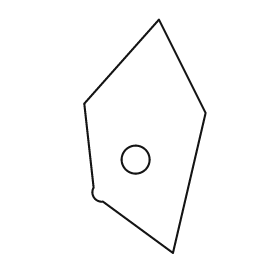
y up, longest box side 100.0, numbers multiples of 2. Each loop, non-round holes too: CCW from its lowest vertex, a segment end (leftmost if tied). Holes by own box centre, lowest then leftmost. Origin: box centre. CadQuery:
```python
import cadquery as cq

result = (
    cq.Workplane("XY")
    .moveTo(12.0, -50.0)
    .lineTo(26.0, 10.0)
    .lineTo(6.0, 50.0)
    .lineTo(-26.0, 14.0)
    .lineTo(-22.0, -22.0)
    .threePointArc((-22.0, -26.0), (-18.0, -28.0))
    .close()
    .moveTo(-4.0, -10.0)
    .circle(6.0)
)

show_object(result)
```